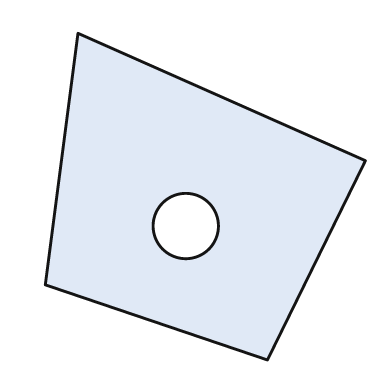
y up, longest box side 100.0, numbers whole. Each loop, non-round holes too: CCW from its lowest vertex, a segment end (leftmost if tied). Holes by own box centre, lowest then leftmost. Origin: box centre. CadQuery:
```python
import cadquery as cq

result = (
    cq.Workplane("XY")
    .moveTo(19.0, -50.0)
    .lineTo(49.0, 11.0)
    .lineTo(-39.0, 50.0)
    .lineTo(-49.0, -27.0)
    .close()
    .moveTo(-6.0, -9.0)
    .circle(10.0)
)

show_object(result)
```